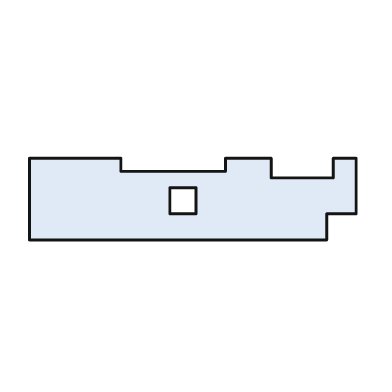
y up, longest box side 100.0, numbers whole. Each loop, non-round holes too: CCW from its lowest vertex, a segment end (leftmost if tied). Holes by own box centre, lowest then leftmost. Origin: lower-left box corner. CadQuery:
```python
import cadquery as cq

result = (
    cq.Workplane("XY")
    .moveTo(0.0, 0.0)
    .lineTo(91.0, 0.0)
    .lineTo(91.0, 8.0)
    .lineTo(100.0, 8.0)
    .lineTo(100.0, 25.0)
    .lineTo(93.0, 25.0)
    .lineTo(93.0, 19.0)
    .lineTo(74.0, 19.0)
    .lineTo(74.0, 25.0)
    .lineTo(60.0, 25.0)
    .lineTo(60.0, 21.0)
    .lineTo(28.0, 21.0)
    .lineTo(28.0, 25.0)
    .lineTo(0.0, 25.0)
    .close()
    .moveTo(43.0, 8.0)
    .lineTo(51.0, 8.0)
    .lineTo(51.0, 16.0)
    .lineTo(43.0, 16.0)
    .close()
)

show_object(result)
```